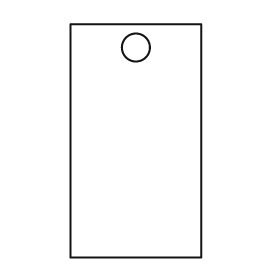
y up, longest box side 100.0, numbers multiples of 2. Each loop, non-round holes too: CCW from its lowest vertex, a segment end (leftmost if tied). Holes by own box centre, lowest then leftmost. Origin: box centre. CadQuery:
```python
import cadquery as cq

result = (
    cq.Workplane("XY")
    .moveTo(-28.0, -50.0)
    .lineTo(28.0, -50.0)
    .lineTo(28.0, 50.0)
    .lineTo(-28.0, 50.0)
    .close()
    .moveTo(0.0, 40.0)
    .circle(6.0)
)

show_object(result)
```